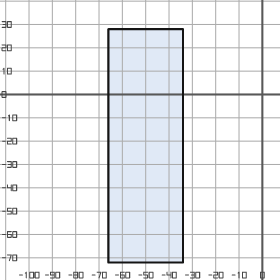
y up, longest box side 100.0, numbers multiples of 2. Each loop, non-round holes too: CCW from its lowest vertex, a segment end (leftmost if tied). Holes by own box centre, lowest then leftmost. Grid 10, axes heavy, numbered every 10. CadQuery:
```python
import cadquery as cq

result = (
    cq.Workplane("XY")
    .moveTo(-66.0, -72.0)
    .lineTo(-34.0, -72.0)
    .lineTo(-34.0, 28.0)
    .lineTo(-66.0, 28.0)
    .close()
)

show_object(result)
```